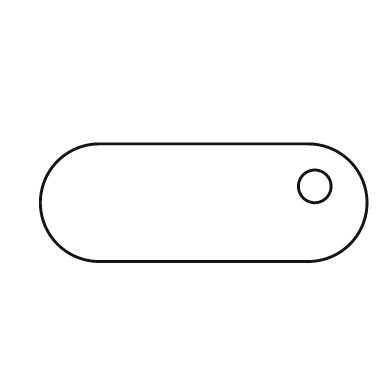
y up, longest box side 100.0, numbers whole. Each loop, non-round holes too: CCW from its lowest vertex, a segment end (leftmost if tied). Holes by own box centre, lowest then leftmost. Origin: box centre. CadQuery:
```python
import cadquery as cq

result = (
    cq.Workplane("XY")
    .moveTo(-32.0, -18.0)
    .lineTo(32.0, -18.0)
    .threePointArc((50.0, 0.0), (32.0, 18.0))
    .lineTo(-32.0, 18.0)
    .threePointArc((-50.0, 0.0), (-32.0, -18.0))
    .close()
    .moveTo(34.0, 5.0)
    .circle(5.0)
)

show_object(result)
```